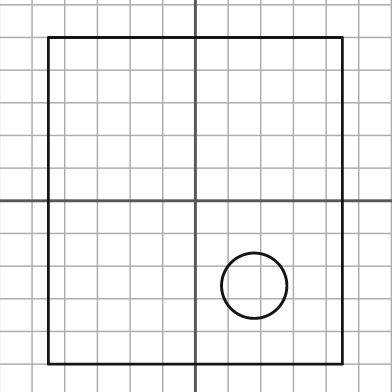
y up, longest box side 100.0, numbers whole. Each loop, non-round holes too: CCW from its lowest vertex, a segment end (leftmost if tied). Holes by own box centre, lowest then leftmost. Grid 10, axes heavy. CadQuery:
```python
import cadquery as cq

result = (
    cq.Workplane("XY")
    .moveTo(-45.0, -50.0)
    .lineTo(45.0, -50.0)
    .lineTo(45.0, 50.0)
    .lineTo(-45.0, 50.0)
    .close()
    .moveTo(18.0, -26.0)
    .circle(10.0)
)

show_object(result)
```